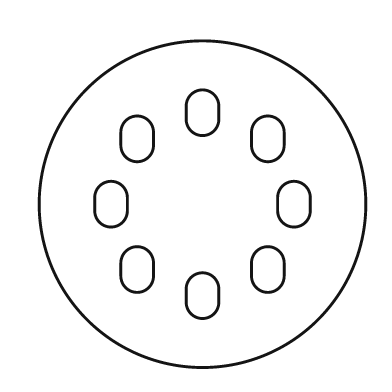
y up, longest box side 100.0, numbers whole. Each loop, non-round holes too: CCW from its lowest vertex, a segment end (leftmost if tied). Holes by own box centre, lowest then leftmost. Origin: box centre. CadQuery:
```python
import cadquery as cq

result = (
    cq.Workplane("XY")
    .moveTo(0.0, 0.0)
    .circle(50.0)
    .moveTo(-5.0, -30.0)
    .threePointArc((0.0, -35.0), (5.0, -30.0))
    .lineTo(5.0, -26.0)
    .threePointArc((0.0, -21.0), (-5.0, -26.0))
    .close()
    .moveTo(-25.0, -22.0)
    .threePointArc((-20.0, -27.0), (-15.0, -22.0))
    .lineTo(-15.0, -18.0)
    .threePointArc((-20.0, -13.0), (-25.0, -18.0))
    .close()
    .moveTo(15.0, -22.0)
    .threePointArc((20.0, -27.0), (25.0, -22.0))
    .lineTo(25.0, -18.0)
    .threePointArc((20.0, -13.0), (15.0, -18.0))
    .close()
    .moveTo(-33.0, -2.0)
    .threePointArc((-28.0, -7.0), (-23.0, -2.0))
    .lineTo(-23.0, 2.0)
    .threePointArc((-28.0, 7.0), (-33.0, 2.0))
    .close()
    .moveTo(23.0, -2.0)
    .threePointArc((28.0, -7.0), (33.0, -2.0))
    .lineTo(33.0, 2.0)
    .threePointArc((28.0, 7.0), (23.0, 2.0))
    .close()
    .moveTo(-25.0, 18.0)
    .threePointArc((-20.0, 13.0), (-15.0, 18.0))
    .lineTo(-15.0, 22.0)
    .threePointArc((-20.0, 27.0), (-25.0, 22.0))
    .close()
    .moveTo(15.0, 18.0)
    .threePointArc((20.0, 13.0), (25.0, 18.0))
    .lineTo(25.0, 22.0)
    .threePointArc((20.0, 27.0), (15.0, 22.0))
    .close()
    .moveTo(-5.0, 26.0)
    .threePointArc((0.0, 21.0), (5.0, 26.0))
    .lineTo(5.0, 30.0)
    .threePointArc((0.0, 35.0), (-5.0, 30.0))
    .close()
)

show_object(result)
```